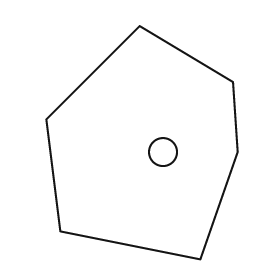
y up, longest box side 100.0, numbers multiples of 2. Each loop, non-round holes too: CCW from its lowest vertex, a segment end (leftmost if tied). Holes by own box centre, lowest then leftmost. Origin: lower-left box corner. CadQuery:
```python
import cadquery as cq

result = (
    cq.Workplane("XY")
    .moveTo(66.0, 0.0)
    .lineTo(82.0, 46.0)
    .lineTo(80.0, 76.0)
    .lineTo(40.0, 100.0)
    .lineTo(0.0, 60.0)
    .lineTo(6.0, 12.0)
    .close()
    .moveTo(50.0, 46.0)
    .circle(6.0)
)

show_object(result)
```